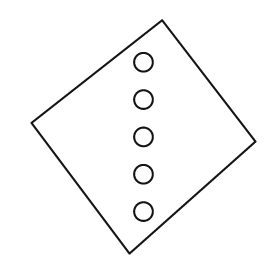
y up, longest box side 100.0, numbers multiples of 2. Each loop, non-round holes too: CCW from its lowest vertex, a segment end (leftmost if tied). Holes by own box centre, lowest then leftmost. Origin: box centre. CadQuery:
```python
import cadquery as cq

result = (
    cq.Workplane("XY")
    .moveTo(-6.0, -50.0)
    .lineTo(48.0, -2.0)
    .lineTo(8.0, 50.0)
    .lineTo(-48.0, 6.0)
    .close()
    .moveTo(0.0, -32.0)
    .circle(4.0)
    .moveTo(0.0, -16.0)
    .circle(4.0)
    .moveTo(0.0, 0.0)
    .circle(4.0)
    .moveTo(0.0, 16.0)
    .circle(4.0)
    .moveTo(0.0, 32.0)
    .circle(4.0)
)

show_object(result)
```